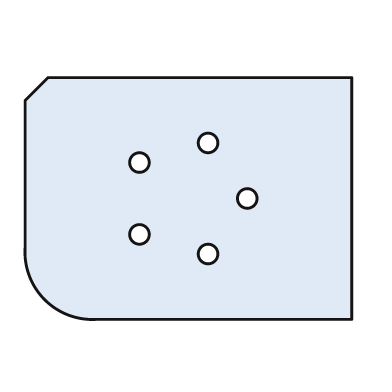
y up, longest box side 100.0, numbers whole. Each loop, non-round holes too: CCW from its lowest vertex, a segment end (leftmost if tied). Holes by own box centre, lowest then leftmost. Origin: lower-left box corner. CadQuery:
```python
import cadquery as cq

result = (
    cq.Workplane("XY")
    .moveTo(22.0, 0.0)
    .lineTo(100.0, 0.0)
    .lineTo(100.0, 74.0)
    .lineTo(7.0, 74.0)
    .lineTo(0.0, 67.0)
    .lineTo(0.0, 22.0)
    .threePointArc((6.0, 6.0), (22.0, 0.0))
    .close()
    .moveTo(56.0, 20.0)
    .circle(3.0)
    .moveTo(35.0, 26.0)
    .circle(3.0)
    .moveTo(68.0, 37.0)
    .circle(3.0)
    .moveTo(35.0, 48.0)
    .circle(3.0)
    .moveTo(56.0, 54.0)
    .circle(3.0)
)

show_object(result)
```